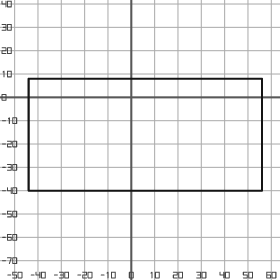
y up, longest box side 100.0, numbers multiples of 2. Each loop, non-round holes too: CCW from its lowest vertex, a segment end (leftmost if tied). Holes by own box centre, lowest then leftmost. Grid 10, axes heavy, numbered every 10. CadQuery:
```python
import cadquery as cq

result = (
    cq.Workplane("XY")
    .moveTo(-44.0, -40.0)
    .lineTo(56.0, -40.0)
    .lineTo(56.0, 8.0)
    .lineTo(-44.0, 8.0)
    .close()
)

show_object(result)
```